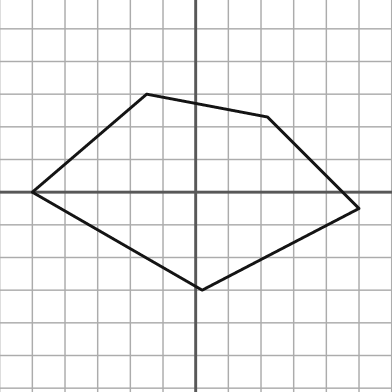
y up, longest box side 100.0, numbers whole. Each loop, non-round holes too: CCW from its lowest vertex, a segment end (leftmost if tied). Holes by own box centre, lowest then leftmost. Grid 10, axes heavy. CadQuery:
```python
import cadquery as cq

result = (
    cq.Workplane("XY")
    .moveTo(2.0, -30.0)
    .lineTo(50.0, -5.0)
    .lineTo(22.0, 23.0)
    .lineTo(-15.0, 30.0)
    .lineTo(-50.0, 0.0)
    .close()
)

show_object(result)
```